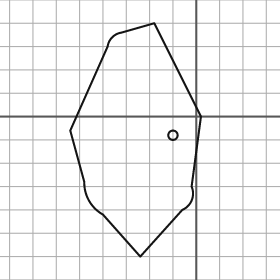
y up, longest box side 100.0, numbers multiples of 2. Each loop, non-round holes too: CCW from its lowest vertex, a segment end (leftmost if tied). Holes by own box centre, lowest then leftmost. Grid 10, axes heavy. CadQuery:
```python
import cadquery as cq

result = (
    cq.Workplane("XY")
    .moveTo(-24.0, -60.0)
    .lineTo(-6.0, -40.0)
    .threePointArc((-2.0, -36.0), (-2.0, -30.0))
    .lineTo(2.0, 0.0)
    .lineTo(-18.0, 40.0)
    .lineTo(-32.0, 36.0)
    .threePointArc((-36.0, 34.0), (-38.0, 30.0))
    .lineTo(-54.0, -6.0)
    .lineTo(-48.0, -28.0)
    .threePointArc((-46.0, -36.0), (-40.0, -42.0))
    .close()
    .moveTo(-10.0, -8.0)
    .circle(2.0)
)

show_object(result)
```